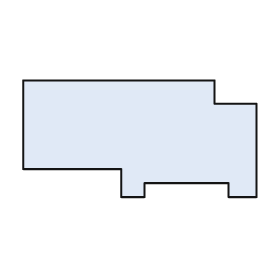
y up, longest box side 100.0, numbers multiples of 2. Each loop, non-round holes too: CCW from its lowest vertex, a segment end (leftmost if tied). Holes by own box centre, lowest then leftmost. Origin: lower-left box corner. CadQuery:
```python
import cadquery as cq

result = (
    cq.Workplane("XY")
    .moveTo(42.0, 0.0)
    .lineTo(52.0, 0.0)
    .lineTo(52.0, 6.0)
    .lineTo(88.0, 6.0)
    .lineTo(88.0, 0.0)
    .lineTo(100.0, 0.0)
    .lineTo(100.0, 40.0)
    .lineTo(82.0, 40.0)
    .lineTo(82.0, 50.0)
    .lineTo(0.0, 50.0)
    .lineTo(0.0, 12.0)
    .lineTo(42.0, 12.0)
    .close()
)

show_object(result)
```